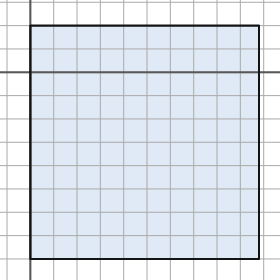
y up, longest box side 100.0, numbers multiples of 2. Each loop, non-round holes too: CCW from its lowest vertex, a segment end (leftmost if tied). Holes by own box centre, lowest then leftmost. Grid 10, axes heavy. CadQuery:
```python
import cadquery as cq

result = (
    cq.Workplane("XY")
    .moveTo(0.0, -80.0)
    .lineTo(98.0, -80.0)
    .lineTo(98.0, 20.0)
    .lineTo(0.0, 20.0)
    .close()
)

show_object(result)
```